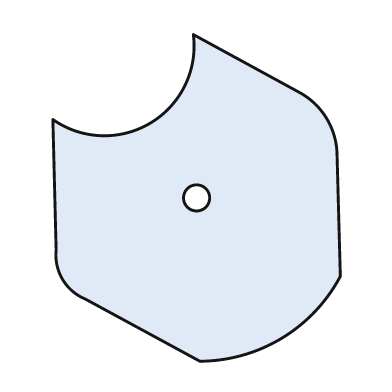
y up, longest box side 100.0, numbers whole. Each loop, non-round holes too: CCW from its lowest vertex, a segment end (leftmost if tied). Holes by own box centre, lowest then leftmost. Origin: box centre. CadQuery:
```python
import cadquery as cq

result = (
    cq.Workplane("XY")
    .moveTo(1.0, -50.0)
    .threePointArc((26.0, -43.0), (44.0, -24.0))
    .lineTo(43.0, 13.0)
    .threePointArc((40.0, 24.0), (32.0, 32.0))
    .lineTo(-1.0, 50.0)
    .threePointArc((-14.0, 23.0), (-44.0, 24.0))
    .lineTo(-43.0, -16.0)
    .threePointArc((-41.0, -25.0), (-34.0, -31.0))
    .close()
    .moveTo(0.0, 0.0)
    .circle(4.0)
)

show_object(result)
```